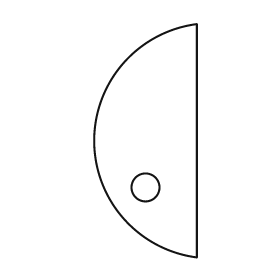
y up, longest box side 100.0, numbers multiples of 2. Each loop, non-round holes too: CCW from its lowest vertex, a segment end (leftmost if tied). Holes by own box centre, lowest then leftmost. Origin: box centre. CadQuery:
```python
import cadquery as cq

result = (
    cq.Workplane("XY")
    .moveTo(22.0, -50.0)
    .lineTo(22.0, 50.0)
    .threePointArc((-22.0, 0.0), (22.0, -50.0))
    .close()
    .moveTo(0.0, -20.0)
    .circle(6.0)
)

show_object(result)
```